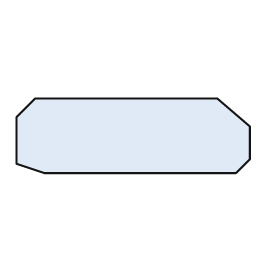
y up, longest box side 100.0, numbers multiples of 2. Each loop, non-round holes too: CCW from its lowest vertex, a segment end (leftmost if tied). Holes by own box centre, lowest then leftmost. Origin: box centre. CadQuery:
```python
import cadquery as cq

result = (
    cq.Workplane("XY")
    .moveTo(-38.0, -16.0)
    .lineTo(44.0, -16.0)
    .lineTo(50.0, -10.0)
    .lineTo(50.0, 4.0)
    .lineTo(36.0, 16.0)
    .lineTo(-42.0, 16.0)
    .lineTo(-50.0, 8.0)
    .lineTo(-50.0, -12.0)
    .close()
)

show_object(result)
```